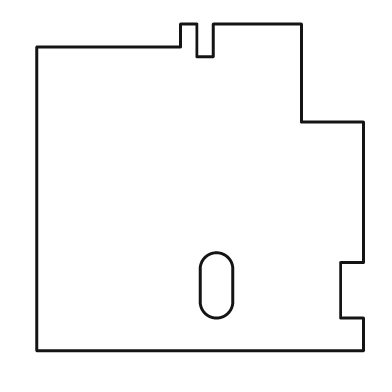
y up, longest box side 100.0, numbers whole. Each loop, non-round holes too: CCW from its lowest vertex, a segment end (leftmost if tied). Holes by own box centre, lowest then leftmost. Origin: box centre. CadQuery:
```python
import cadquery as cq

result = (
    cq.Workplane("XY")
    .moveTo(-50.0, -50.0)
    .lineTo(50.0, -50.0)
    .lineTo(50.0, -40.0)
    .lineTo(43.0, -40.0)
    .lineTo(43.0, -23.0)
    .lineTo(50.0, -23.0)
    .lineTo(50.0, 20.0)
    .lineTo(31.0, 20.0)
    .lineTo(31.0, 50.0)
    .lineTo(4.0, 50.0)
    .lineTo(4.0, 40.0)
    .lineTo(-1.0, 40.0)
    .lineTo(-1.0, 50.0)
    .lineTo(-6.0, 50.0)
    .lineTo(-6.0, 43.0)
    .lineTo(-50.0, 43.0)
    .close()
    .moveTo(0.0, -35.0)
    .threePointArc((5.0, -40.0), (10.0, -35.0))
    .lineTo(10.0, -25.0)
    .threePointArc((5.0, -20.0), (0.0, -25.0))
    .close()
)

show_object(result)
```